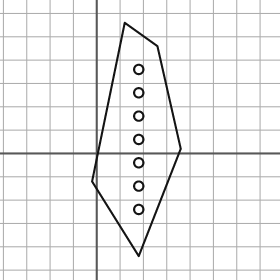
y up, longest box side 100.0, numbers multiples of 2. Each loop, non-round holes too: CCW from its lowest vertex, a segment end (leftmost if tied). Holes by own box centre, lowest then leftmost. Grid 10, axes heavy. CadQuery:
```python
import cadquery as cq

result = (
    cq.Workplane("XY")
    .moveTo(18.0, -44.0)
    .lineTo(36.0, 2.0)
    .lineTo(26.0, 46.0)
    .lineTo(12.0, 56.0)
    .lineTo(-2.0, -12.0)
    .close()
    .moveTo(18.0, -24.0)
    .circle(2.0)
    .moveTo(18.0, -14.0)
    .circle(2.0)
    .moveTo(18.0, -4.0)
    .circle(2.0)
    .moveTo(18.0, 6.0)
    .circle(2.0)
    .moveTo(18.0, 16.0)
    .circle(2.0)
    .moveTo(18.0, 26.0)
    .circle(2.0)
    .moveTo(18.0, 36.0)
    .circle(2.0)
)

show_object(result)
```